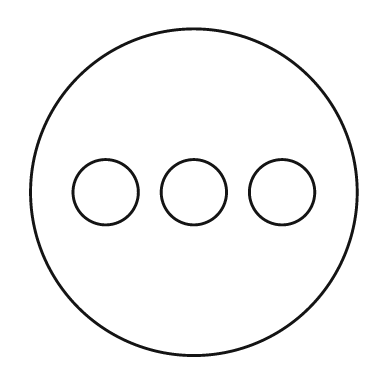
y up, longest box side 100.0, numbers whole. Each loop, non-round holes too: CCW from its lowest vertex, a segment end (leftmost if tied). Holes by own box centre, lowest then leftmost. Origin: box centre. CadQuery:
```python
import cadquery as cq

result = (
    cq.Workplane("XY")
    .moveTo(0.0, 0.0)
    .circle(50.0)
    .moveTo(-27.0, 0.0)
    .circle(10.0)
    .moveTo(0.0, 0.0)
    .circle(10.0)
    .moveTo(27.0, 0.0)
    .circle(10.0)
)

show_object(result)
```